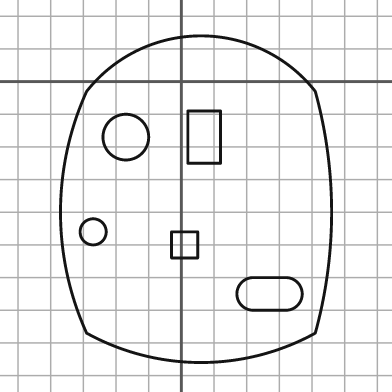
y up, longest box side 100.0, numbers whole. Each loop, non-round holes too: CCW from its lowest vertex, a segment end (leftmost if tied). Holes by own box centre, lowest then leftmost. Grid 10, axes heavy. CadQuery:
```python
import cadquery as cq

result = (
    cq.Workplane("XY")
    .moveTo(-29.0, -77.0)
    .threePointArc((6.0, -86.0), (41.0, -77.0))
    .threePointArc((46.0, -40.0), (41.0, -3.0))
    .threePointArc((6.0, 14.0), (-29.0, -3.0))
    .threePointArc((-37.0, -40.0), (-29.0, -77.0))
    .close()
    .moveTo(22.0, -70.0)
    .lineTo(32.0, -70.0)
    .threePointArc((37.0, -65.0), (32.0, -60.0))
    .lineTo(22.0, -60.0)
    .threePointArc((17.0, -65.0), (22.0, -70.0))
    .close()
    .moveTo(-3.0, -54.0)
    .lineTo(5.0, -54.0)
    .lineTo(5.0, -46.0)
    .lineTo(-3.0, -46.0)
    .close()
    .moveTo(-27.0, -46.0)
    .circle(4.0)
    .moveTo(-17.0, -17.0)
    .circle(7.0)
    .moveTo(2.0, -25.0)
    .lineTo(12.0, -25.0)
    .lineTo(12.0, -9.0)
    .lineTo(2.0, -9.0)
    .close()
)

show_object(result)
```